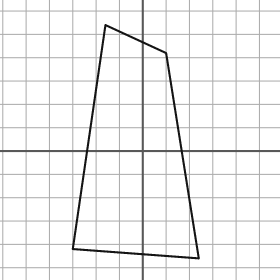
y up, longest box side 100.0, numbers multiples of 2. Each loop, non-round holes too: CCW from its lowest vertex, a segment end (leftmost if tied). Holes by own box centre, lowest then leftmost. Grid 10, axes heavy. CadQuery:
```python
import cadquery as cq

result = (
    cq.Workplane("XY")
    .moveTo(24.0, -46.0)
    .lineTo(10.0, 42.0)
    .lineTo(-16.0, 54.0)
    .lineTo(-30.0, -42.0)
    .close()
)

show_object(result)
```